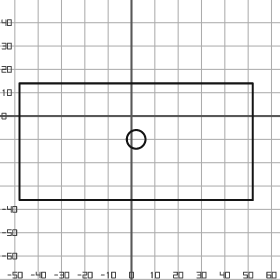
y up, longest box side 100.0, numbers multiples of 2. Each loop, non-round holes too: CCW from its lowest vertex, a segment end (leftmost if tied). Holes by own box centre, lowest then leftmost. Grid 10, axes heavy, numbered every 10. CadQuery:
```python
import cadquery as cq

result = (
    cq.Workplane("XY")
    .moveTo(-48.0, -36.0)
    .lineTo(52.0, -36.0)
    .lineTo(52.0, 14.0)
    .lineTo(-48.0, 14.0)
    .close()
    .moveTo(2.0, -10.0)
    .circle(4.0)
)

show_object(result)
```